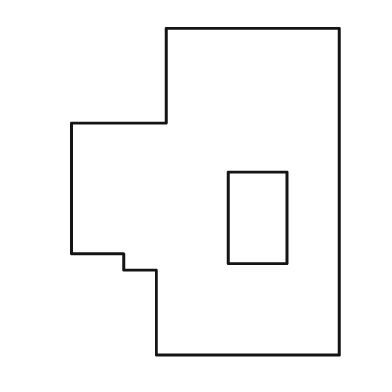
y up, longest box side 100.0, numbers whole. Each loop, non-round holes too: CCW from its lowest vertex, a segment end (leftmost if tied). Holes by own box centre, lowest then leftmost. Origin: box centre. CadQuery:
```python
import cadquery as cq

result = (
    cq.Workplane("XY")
    .moveTo(-15.0, -50.0)
    .lineTo(41.0, -50.0)
    .lineTo(41.0, 50.0)
    .lineTo(-12.0, 50.0)
    .lineTo(-12.0, 21.0)
    .lineTo(-41.0, 21.0)
    .lineTo(-41.0, -19.0)
    .lineTo(-25.0, -19.0)
    .lineTo(-25.0, -24.0)
    .lineTo(-15.0, -24.0)
    .close()
    .moveTo(7.0, -22.0)
    .lineTo(25.0, -22.0)
    .lineTo(25.0, 6.0)
    .lineTo(7.0, 6.0)
    .close()
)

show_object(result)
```